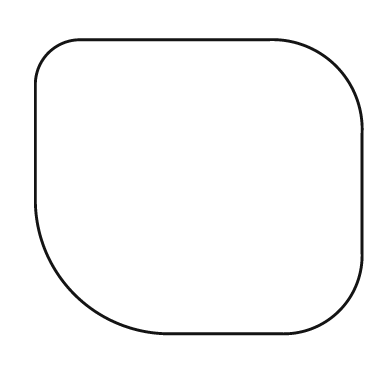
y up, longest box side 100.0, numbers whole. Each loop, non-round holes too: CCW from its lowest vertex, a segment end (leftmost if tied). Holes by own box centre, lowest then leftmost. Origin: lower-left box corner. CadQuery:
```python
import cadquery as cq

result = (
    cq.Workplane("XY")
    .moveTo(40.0, 0.0)
    .lineTo(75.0, 0.0)
    .threePointArc((93.0, 7.0), (100.0, 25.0))
    .lineTo(100.0, 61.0)
    .threePointArc((92.0, 82.0), (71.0, 90.0))
    .lineTo(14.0, 90.0)
    .threePointArc((4.0, 86.0), (0.0, 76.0))
    .lineTo(0.0, 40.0)
    .threePointArc((12.0, 12.0), (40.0, 0.0))
    .close()
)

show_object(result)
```